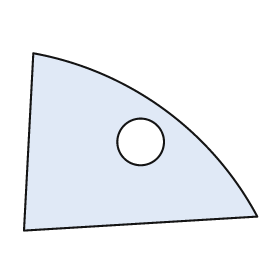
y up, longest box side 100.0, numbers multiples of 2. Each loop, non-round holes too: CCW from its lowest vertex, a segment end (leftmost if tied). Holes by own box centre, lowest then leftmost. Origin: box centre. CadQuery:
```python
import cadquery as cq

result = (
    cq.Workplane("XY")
    .moveTo(-50.0, -38.0)
    .lineTo(50.0, -32.0)
    .threePointArc((10.0, 14.0), (-46.0, 38.0))
    .close()
    .moveTo(0.0, 0.0)
    .circle(10.0)
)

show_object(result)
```